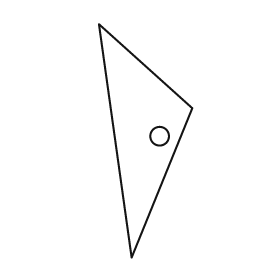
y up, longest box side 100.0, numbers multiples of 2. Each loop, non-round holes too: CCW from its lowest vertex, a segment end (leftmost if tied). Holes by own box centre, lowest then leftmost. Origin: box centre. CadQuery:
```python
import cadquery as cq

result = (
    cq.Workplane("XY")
    .moveTo(-6.0, -50.0)
    .lineTo(20.0, 14.0)
    .lineTo(-20.0, 50.0)
    .close()
    .moveTo(6.0, 2.0)
    .circle(4.0)
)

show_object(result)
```